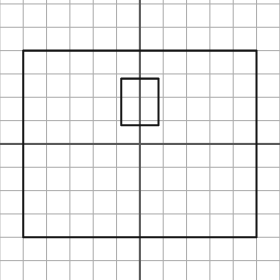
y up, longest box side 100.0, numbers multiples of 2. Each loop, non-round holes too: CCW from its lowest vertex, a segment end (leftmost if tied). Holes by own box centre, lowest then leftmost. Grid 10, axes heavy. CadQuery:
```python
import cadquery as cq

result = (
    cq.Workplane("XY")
    .moveTo(-50.0, -40.0)
    .lineTo(50.0, -40.0)
    .lineTo(50.0, 40.0)
    .lineTo(-50.0, 40.0)
    .close()
    .moveTo(-8.0, 8.0)
    .lineTo(8.0, 8.0)
    .lineTo(8.0, 28.0)
    .lineTo(-8.0, 28.0)
    .close()
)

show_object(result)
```